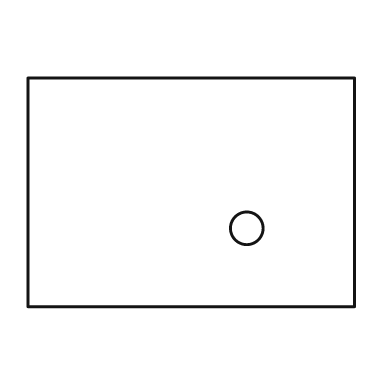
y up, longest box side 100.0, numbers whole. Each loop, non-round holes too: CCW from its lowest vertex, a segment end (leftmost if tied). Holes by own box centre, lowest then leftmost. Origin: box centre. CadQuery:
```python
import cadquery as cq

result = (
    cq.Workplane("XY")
    .moveTo(-50.0, -35.0)
    .lineTo(50.0, -35.0)
    .lineTo(50.0, 35.0)
    .lineTo(-50.0, 35.0)
    .close()
    .moveTo(17.0, -11.0)
    .circle(5.0)
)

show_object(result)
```